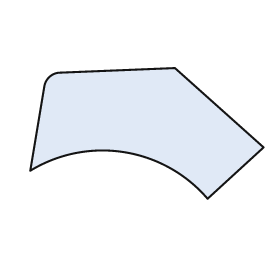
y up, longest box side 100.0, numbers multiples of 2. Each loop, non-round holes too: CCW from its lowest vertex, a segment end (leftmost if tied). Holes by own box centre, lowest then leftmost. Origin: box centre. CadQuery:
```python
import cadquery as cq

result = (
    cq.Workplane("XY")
    .moveTo(26.0, -28.0)
    .lineTo(50.0, -6.0)
    .lineTo(12.0, 28.0)
    .lineTo(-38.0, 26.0)
    .threePointArc((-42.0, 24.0), (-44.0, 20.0))
    .lineTo(-50.0, -16.0)
    .threePointArc((-10.0, -8.0), (26.0, -28.0))
    .close()
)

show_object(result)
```